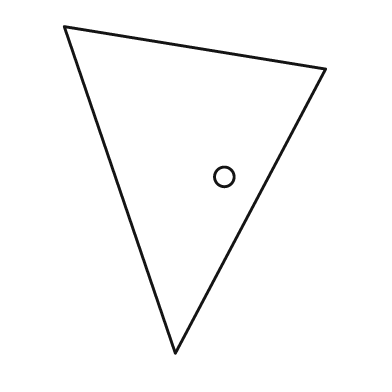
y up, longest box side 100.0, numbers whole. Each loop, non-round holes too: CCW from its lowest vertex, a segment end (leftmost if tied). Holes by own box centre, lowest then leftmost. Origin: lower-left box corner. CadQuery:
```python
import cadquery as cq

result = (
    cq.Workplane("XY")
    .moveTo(34.0, 0.0)
    .lineTo(80.0, 87.0)
    .lineTo(0.0, 100.0)
    .close()
    .moveTo(49.0, 54.0)
    .circle(3.0)
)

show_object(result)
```